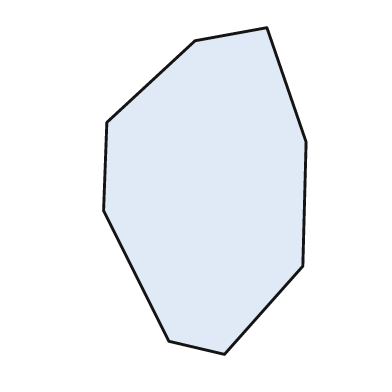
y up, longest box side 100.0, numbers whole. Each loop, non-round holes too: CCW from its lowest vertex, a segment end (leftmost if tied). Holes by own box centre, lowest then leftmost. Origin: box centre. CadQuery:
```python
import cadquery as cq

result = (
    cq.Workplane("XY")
    .moveTo(6.0, -50.0)
    .lineTo(30.0, -23.0)
    .lineTo(31.0, 15.0)
    .lineTo(19.0, 50.0)
    .lineTo(-3.0, 46.0)
    .lineTo(-30.0, 21.0)
    .lineTo(-31.0, -6.0)
    .lineTo(-11.0, -46.0)
    .close()
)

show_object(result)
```